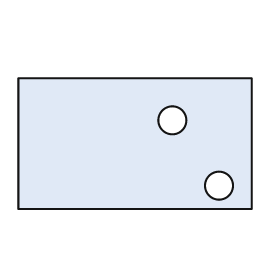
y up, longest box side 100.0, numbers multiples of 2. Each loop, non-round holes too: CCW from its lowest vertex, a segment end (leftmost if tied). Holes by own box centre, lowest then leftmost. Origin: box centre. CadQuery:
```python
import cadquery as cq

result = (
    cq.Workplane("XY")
    .moveTo(-50.0, -28.0)
    .lineTo(50.0, -28.0)
    .lineTo(50.0, 28.0)
    .lineTo(-50.0, 28.0)
    .close()
    .moveTo(36.0, -18.0)
    .circle(6.0)
    .moveTo(16.0, 10.0)
    .circle(6.0)
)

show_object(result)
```